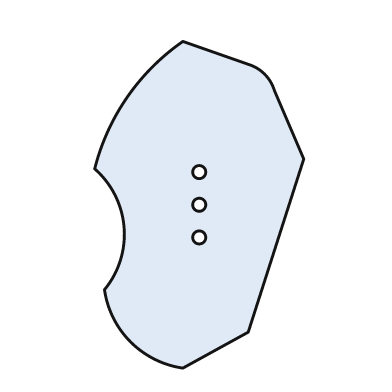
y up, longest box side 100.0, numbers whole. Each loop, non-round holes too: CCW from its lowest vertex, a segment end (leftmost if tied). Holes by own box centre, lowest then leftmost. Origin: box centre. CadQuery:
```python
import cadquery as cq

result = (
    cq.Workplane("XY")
    .moveTo(-5.0, -50.0)
    .lineTo(15.0, -39.0)
    .lineTo(32.0, 14.0)
    .lineTo(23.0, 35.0)
    .threePointArc((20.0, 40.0), (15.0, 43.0))
    .lineTo(-5.0, 50.0)
    .threePointArc((-22.0, 33.0), (-32.0, 11.0))
    .threePointArc((-23.0, -7.0), (-29.0, -26.0))
    .threePointArc((-21.0, -42.0), (-5.0, -50.0))
    .close()
    .moveTo(0.0, -10.0)
    .circle(2.0)
    .moveTo(0.0, 0.0)
    .circle(2.0)
    .moveTo(0.0, 10.0)
    .circle(2.0)
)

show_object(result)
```